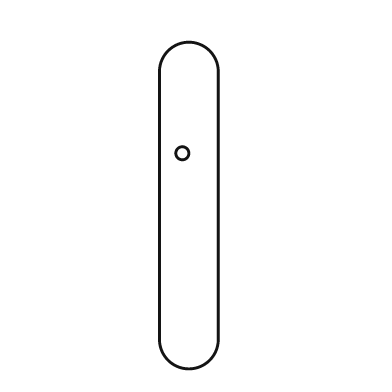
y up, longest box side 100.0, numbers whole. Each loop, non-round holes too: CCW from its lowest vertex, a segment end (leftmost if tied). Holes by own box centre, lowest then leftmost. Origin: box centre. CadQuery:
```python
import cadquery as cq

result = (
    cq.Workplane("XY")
    .moveTo(-9.0, -41.0)
    .threePointArc((0.0, -50.0), (9.0, -41.0))
    .lineTo(9.0, 41.0)
    .threePointArc((0.0, 50.0), (-9.0, 41.0))
    .close()
    .moveTo(-2.0, 16.0)
    .circle(2.0)
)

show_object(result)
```